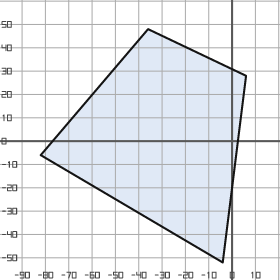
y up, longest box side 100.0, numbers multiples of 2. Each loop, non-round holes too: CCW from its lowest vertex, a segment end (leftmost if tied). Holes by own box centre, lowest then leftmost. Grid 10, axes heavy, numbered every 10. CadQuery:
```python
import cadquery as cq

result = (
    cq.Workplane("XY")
    .moveTo(-4.0, -52.0)
    .lineTo(6.0, 28.0)
    .lineTo(-36.0, 48.0)
    .lineTo(-82.0, -6.0)
    .close()
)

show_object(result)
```